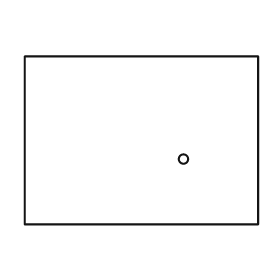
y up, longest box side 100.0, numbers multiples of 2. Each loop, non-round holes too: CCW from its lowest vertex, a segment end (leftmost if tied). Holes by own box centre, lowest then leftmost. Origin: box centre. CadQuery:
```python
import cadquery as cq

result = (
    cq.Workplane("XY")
    .moveTo(-50.0, -36.0)
    .lineTo(50.0, -36.0)
    .lineTo(50.0, 36.0)
    .lineTo(-50.0, 36.0)
    .close()
    .moveTo(18.0, -8.0)
    .circle(2.0)
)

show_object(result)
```